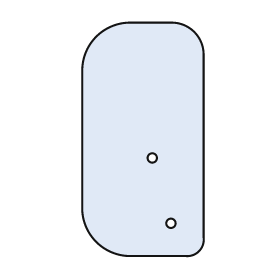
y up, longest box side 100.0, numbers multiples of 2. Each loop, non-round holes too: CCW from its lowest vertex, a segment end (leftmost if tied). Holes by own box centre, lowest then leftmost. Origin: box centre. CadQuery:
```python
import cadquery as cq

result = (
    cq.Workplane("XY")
    .moveTo(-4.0, -50.0)
    .lineTo(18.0, -50.0)
    .threePointArc((24.0, -48.0), (26.0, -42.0))
    .lineTo(26.0, 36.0)
    .threePointArc((22.0, 46.0), (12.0, 50.0))
    .lineTo(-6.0, 50.0)
    .threePointArc((-20.0, 44.0), (-26.0, 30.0))
    .lineTo(-26.0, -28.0)
    .threePointArc((-20.0, -44.0), (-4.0, -50.0))
    .close()
    .moveTo(12.0, -36.0)
    .circle(2.0)
    .moveTo(4.0, -8.0)
    .circle(2.0)
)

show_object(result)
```